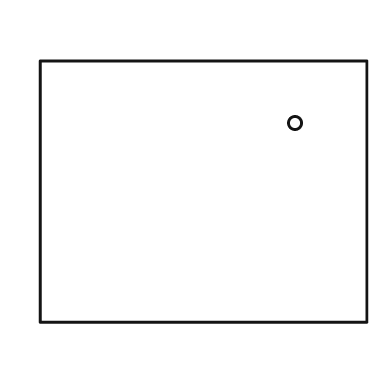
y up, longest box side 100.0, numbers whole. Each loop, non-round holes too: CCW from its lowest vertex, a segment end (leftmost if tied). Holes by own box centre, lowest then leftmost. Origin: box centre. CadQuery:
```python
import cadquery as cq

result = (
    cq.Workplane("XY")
    .moveTo(-50.0, -40.0)
    .lineTo(50.0, -40.0)
    .lineTo(50.0, 40.0)
    .lineTo(-50.0, 40.0)
    .close()
    .moveTo(28.0, 21.0)
    .circle(2.0)
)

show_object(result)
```